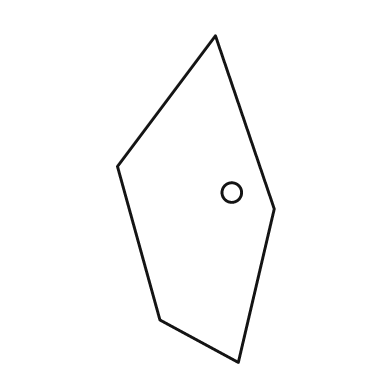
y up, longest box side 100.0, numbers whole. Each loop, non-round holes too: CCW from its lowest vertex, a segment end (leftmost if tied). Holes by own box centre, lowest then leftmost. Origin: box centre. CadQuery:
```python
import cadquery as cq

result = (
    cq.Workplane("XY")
    .moveTo(13.0, -50.0)
    .lineTo(24.0, -3.0)
    .lineTo(6.0, 50.0)
    .lineTo(-24.0, 10.0)
    .lineTo(-11.0, -37.0)
    .close()
    .moveTo(11.0, 2.0)
    .circle(3.0)
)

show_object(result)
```